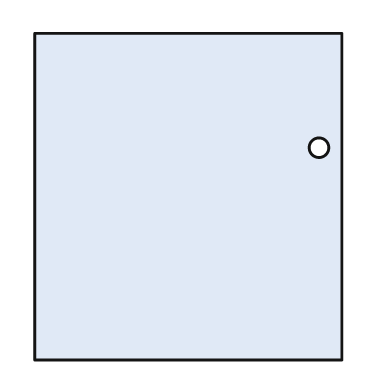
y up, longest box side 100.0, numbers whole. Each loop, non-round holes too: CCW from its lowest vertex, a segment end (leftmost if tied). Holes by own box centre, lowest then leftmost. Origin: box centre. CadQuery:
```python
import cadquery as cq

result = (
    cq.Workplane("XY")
    .moveTo(-47.0, -50.0)
    .lineTo(47.0, -50.0)
    .lineTo(47.0, 50.0)
    .lineTo(-47.0, 50.0)
    .close()
    .moveTo(40.0, 15.0)
    .circle(3.0)
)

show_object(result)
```